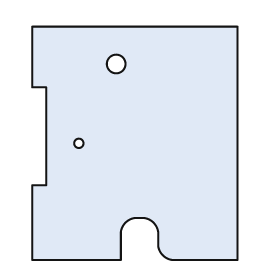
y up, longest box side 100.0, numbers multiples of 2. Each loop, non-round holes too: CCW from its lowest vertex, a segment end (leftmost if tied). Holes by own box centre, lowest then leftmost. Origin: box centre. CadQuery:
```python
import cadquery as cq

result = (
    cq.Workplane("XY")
    .moveTo(-44.0, -50.0)
    .lineTo(-6.0, -50.0)
    .lineTo(-6.0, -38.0)
    .threePointArc((-4.0, -34.0), (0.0, -32.0))
    .lineTo(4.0, -32.0)
    .threePointArc((8.0, -34.0), (10.0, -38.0))
    .lineTo(10.0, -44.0)
    .threePointArc((12.0, -48.0), (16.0, -50.0))
    .lineTo(44.0, -50.0)
    .lineTo(44.0, 50.0)
    .lineTo(-44.0, 50.0)
    .lineTo(-44.0, 24.0)
    .lineTo(-38.0, 24.0)
    .lineTo(-38.0, -18.0)
    .lineTo(-44.0, -18.0)
    .close()
    .moveTo(-24.0, 0.0)
    .circle(2.0)
    .moveTo(-8.0, 34.0)
    .circle(4.0)
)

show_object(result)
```